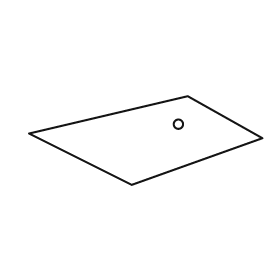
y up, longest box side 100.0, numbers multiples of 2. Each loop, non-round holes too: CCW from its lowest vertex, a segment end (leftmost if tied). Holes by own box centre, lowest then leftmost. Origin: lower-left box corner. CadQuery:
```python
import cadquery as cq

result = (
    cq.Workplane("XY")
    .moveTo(44.0, 0.0)
    .lineTo(100.0, 20.0)
    .lineTo(68.0, 38.0)
    .lineTo(0.0, 22.0)
    .close()
    .moveTo(64.0, 26.0)
    .circle(2.0)
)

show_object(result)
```